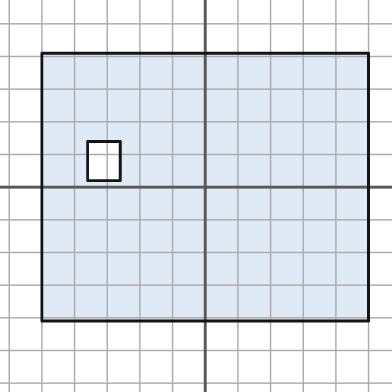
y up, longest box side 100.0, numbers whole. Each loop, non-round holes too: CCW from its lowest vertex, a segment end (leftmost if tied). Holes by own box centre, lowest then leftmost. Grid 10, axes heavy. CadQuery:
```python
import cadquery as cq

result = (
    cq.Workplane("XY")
    .moveTo(-50.0, -41.0)
    .lineTo(50.0, -41.0)
    .lineTo(50.0, 41.0)
    .lineTo(-50.0, 41.0)
    .close()
    .moveTo(-36.0, 2.0)
    .lineTo(-26.0, 2.0)
    .lineTo(-26.0, 14.0)
    .lineTo(-36.0, 14.0)
    .close()
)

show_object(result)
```